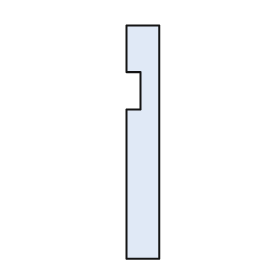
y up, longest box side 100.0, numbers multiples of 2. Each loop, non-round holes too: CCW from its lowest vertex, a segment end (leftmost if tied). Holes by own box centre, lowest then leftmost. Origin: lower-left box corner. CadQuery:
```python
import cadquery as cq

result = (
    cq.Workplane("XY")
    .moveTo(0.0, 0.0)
    .lineTo(14.0, 0.0)
    .lineTo(14.0, 100.0)
    .lineTo(0.0, 100.0)
    .lineTo(0.0, 80.0)
    .lineTo(6.0, 80.0)
    .lineTo(6.0, 64.0)
    .lineTo(0.0, 64.0)
    .close()
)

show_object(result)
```